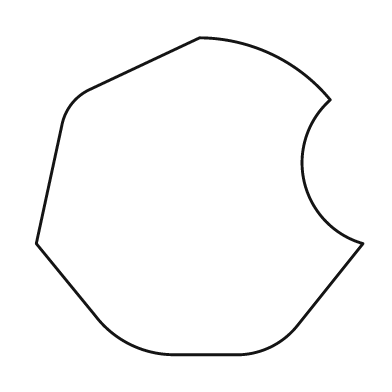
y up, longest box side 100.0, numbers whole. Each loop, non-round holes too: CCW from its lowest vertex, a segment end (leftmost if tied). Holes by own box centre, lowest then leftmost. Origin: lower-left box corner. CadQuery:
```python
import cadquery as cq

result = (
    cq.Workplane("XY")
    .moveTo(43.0, 0.0)
    .lineTo(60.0, 0.0)
    .threePointArc((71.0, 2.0), (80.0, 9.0))
    .lineTo(100.0, 34.0)
    .threePointArc((82.0, 53.0), (90.0, 78.0))
    .threePointArc((72.0, 92.0), (50.0, 97.0))
    .lineTo(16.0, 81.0)
    .threePointArc((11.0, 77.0), (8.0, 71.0))
    .lineTo(0.0, 34.0)
    .lineTo(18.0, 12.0)
    .threePointArc((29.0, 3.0), (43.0, 0.0))
    .close()
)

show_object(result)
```